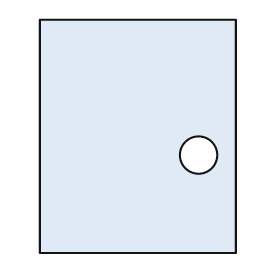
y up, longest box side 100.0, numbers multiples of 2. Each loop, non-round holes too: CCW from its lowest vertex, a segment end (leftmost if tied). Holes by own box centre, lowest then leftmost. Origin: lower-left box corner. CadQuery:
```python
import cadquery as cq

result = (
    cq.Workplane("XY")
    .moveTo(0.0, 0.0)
    .lineTo(84.0, 0.0)
    .lineTo(84.0, 100.0)
    .lineTo(0.0, 100.0)
    .close()
    .moveTo(68.0, 42.0)
    .circle(8.0)
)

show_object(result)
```